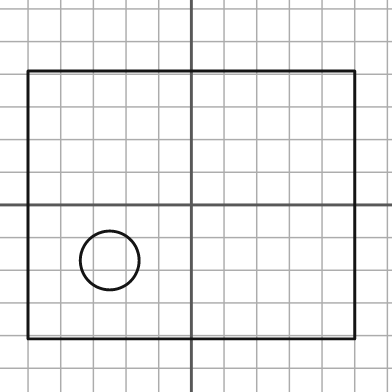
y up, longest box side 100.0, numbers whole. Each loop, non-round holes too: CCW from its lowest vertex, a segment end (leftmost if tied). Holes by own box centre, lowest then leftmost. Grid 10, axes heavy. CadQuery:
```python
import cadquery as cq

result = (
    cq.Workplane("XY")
    .moveTo(-50.0, -41.0)
    .lineTo(50.0, -41.0)
    .lineTo(50.0, 41.0)
    .lineTo(-50.0, 41.0)
    .close()
    .moveTo(-25.0, -17.0)
    .circle(9.0)
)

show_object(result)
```